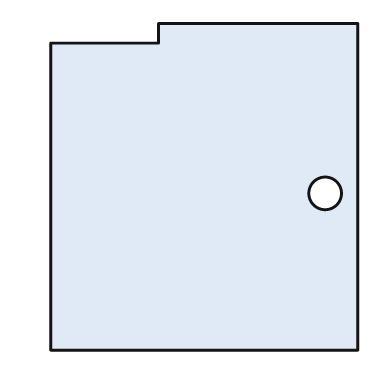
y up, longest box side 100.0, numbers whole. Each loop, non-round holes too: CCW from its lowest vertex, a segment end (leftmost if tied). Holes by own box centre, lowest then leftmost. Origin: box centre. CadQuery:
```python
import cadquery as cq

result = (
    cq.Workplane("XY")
    .moveTo(-47.0, -50.0)
    .lineTo(47.0, -50.0)
    .lineTo(47.0, 50.0)
    .lineTo(-14.0, 50.0)
    .lineTo(-14.0, 44.0)
    .lineTo(-47.0, 44.0)
    .close()
    .moveTo(37.0, -2.0)
    .circle(5.0)
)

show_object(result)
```